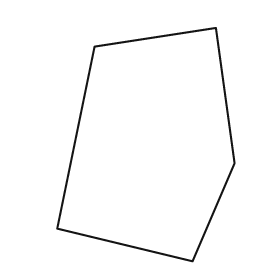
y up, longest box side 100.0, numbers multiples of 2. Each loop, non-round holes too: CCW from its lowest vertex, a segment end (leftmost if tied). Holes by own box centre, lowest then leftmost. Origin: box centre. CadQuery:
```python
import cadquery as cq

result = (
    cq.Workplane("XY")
    .moveTo(20.0, -50.0)
    .lineTo(38.0, -8.0)
    .lineTo(30.0, 50.0)
    .lineTo(-22.0, 42.0)
    .lineTo(-38.0, -36.0)
    .close()
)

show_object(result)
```